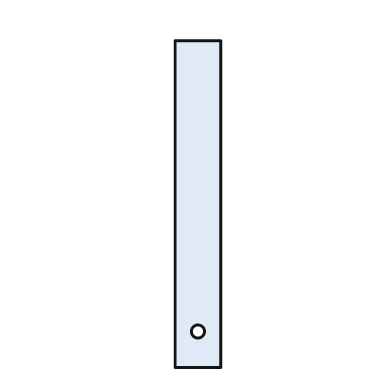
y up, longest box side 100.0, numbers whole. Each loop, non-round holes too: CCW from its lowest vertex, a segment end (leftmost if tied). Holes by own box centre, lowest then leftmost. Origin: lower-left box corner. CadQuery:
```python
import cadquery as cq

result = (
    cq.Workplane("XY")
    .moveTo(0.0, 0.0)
    .lineTo(14.0, 0.0)
    .lineTo(14.0, 100.0)
    .lineTo(0.0, 100.0)
    .close()
    .moveTo(7.0, 11.0)
    .circle(2.0)
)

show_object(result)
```